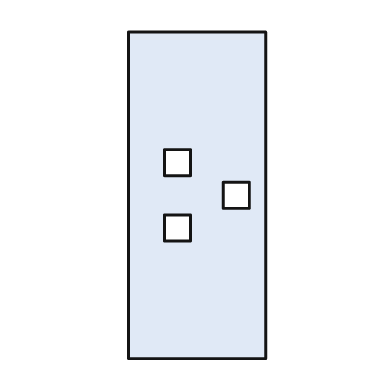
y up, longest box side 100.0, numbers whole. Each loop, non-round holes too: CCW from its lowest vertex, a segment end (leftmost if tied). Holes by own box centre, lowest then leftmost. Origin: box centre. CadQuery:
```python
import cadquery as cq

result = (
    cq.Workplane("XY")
    .moveTo(-21.0, -50.0)
    .lineTo(21.0, -50.0)
    .lineTo(21.0, 50.0)
    .lineTo(-21.0, 50.0)
    .close()
    .moveTo(-10.0, -14.0)
    .lineTo(-2.0, -14.0)
    .lineTo(-2.0, -6.0)
    .lineTo(-10.0, -6.0)
    .close()
    .moveTo(8.0, -4.0)
    .lineTo(16.0, -4.0)
    .lineTo(16.0, 4.0)
    .lineTo(8.0, 4.0)
    .close()
    .moveTo(-10.0, 6.0)
    .lineTo(-2.0, 6.0)
    .lineTo(-2.0, 14.0)
    .lineTo(-10.0, 14.0)
    .close()
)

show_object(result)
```